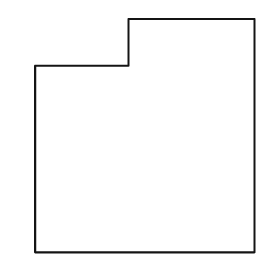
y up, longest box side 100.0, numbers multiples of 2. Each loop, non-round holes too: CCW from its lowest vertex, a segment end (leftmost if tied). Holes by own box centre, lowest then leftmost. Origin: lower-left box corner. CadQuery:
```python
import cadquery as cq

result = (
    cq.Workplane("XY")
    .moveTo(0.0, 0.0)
    .lineTo(94.0, 0.0)
    .lineTo(94.0, 100.0)
    .lineTo(40.0, 100.0)
    .lineTo(40.0, 80.0)
    .lineTo(0.0, 80.0)
    .close()
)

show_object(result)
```